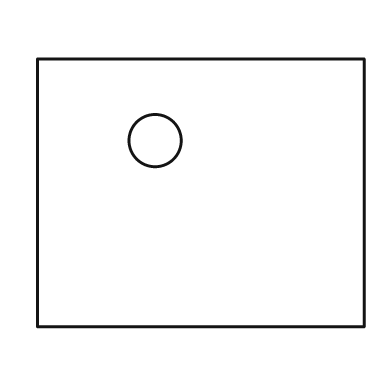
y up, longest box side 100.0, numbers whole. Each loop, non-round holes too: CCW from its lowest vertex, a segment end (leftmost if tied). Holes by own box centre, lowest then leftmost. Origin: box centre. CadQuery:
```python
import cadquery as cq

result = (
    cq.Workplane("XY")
    .moveTo(-50.0, -41.0)
    .lineTo(50.0, -41.0)
    .lineTo(50.0, 41.0)
    .lineTo(-50.0, 41.0)
    .close()
    .moveTo(-14.0, 16.0)
    .circle(8.0)
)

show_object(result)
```